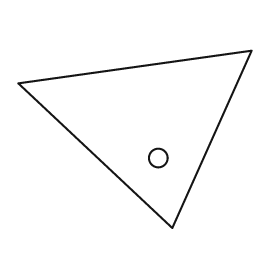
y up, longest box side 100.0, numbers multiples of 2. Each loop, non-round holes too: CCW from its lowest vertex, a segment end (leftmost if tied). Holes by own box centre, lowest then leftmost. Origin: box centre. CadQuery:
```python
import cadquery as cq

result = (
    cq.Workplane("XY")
    .moveTo(16.0, -38.0)
    .lineTo(50.0, 38.0)
    .lineTo(-50.0, 24.0)
    .close()
    .moveTo(10.0, -8.0)
    .circle(4.0)
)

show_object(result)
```